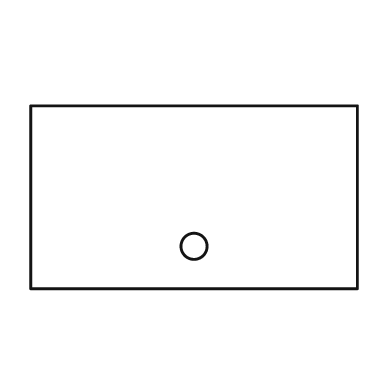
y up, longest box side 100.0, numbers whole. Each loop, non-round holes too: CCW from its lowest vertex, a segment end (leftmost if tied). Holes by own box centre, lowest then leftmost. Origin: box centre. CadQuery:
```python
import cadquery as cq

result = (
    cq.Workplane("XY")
    .moveTo(-50.0, -28.0)
    .lineTo(50.0, -28.0)
    .lineTo(50.0, 28.0)
    .lineTo(-50.0, 28.0)
    .close()
    .moveTo(0.0, -15.0)
    .circle(4.0)
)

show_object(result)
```